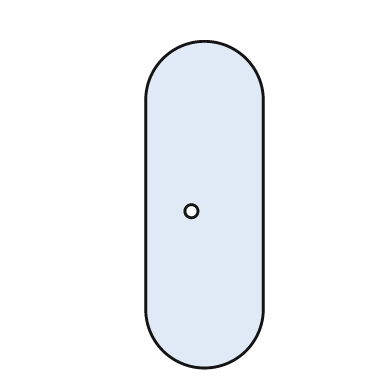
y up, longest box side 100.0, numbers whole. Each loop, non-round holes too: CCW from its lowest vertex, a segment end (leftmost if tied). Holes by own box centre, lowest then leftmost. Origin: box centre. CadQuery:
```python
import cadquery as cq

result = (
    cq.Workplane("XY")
    .moveTo(-18.0, -32.0)
    .threePointArc((0.0, -50.0), (18.0, -32.0))
    .lineTo(18.0, 32.0)
    .threePointArc((0.0, 50.0), (-18.0, 32.0))
    .close()
    .moveTo(-4.0, -2.0)
    .circle(2.0)
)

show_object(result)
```